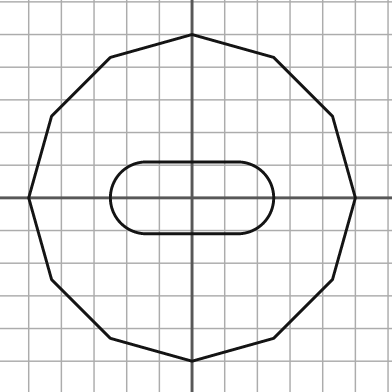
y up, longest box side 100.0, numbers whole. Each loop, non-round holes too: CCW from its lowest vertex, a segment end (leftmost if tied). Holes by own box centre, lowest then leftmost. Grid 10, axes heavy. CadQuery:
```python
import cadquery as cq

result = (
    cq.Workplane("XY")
    .moveTo(0.0, -50.0)
    .lineTo(25.0, -43.0)
    .lineTo(43.0, -25.0)
    .lineTo(50.0, 0.0)
    .lineTo(43.0, 25.0)
    .lineTo(25.0, 43.0)
    .lineTo(0.0, 50.0)
    .lineTo(-25.0, 43.0)
    .lineTo(-43.0, 25.0)
    .lineTo(-50.0, 0.0)
    .lineTo(-43.0, -25.0)
    .lineTo(-25.0, -43.0)
    .close()
    .moveTo(-14.0, -11.0)
    .lineTo(14.0, -11.0)
    .threePointArc((25.0, 0.0), (14.0, 11.0))
    .lineTo(-14.0, 11.0)
    .threePointArc((-25.0, 0.0), (-14.0, -11.0))
    .close()
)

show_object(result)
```